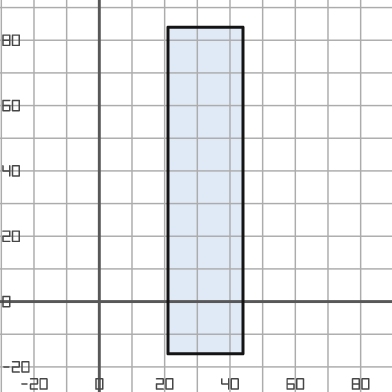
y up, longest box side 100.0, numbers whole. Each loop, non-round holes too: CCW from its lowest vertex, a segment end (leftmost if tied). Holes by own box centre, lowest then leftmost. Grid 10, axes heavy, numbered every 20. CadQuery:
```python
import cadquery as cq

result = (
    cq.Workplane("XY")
    .moveTo(21.0, -16.0)
    .lineTo(44.0, -16.0)
    .lineTo(44.0, 84.0)
    .lineTo(21.0, 84.0)
    .close()
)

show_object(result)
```